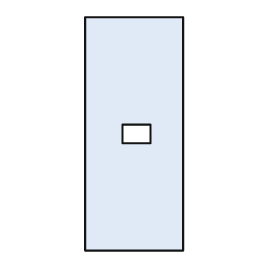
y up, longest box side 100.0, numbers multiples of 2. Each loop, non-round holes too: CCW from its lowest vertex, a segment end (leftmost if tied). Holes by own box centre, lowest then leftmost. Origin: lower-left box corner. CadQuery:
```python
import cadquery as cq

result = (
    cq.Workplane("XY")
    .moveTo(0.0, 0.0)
    .lineTo(42.0, 0.0)
    .lineTo(42.0, 100.0)
    .lineTo(0.0, 100.0)
    .close()
    .moveTo(16.0, 46.0)
    .lineTo(28.0, 46.0)
    .lineTo(28.0, 54.0)
    .lineTo(16.0, 54.0)
    .close()
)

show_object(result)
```